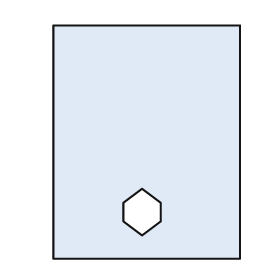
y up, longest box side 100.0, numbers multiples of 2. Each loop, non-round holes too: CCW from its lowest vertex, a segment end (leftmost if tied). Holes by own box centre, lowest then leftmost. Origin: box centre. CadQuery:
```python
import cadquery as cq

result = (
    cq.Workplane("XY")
    .moveTo(-40.0, -50.0)
    .lineTo(40.0, -50.0)
    .lineTo(40.0, 50.0)
    .lineTo(-40.0, 50.0)
    .close()
    .moveTo(-2.0, -40.0)
    .lineTo(6.0, -34.0)
    .lineTo(6.0, -26.0)
    .lineTo(-2.0, -20.0)
    .lineTo(-10.0, -26.0)
    .lineTo(-10.0, -34.0)
    .close()
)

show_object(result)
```